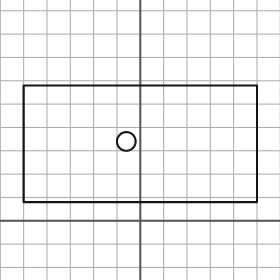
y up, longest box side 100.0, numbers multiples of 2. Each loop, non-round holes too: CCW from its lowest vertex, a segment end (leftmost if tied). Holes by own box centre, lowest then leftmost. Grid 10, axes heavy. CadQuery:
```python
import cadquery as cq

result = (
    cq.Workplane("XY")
    .moveTo(-50.0, 8.0)
    .lineTo(50.0, 8.0)
    .lineTo(50.0, 58.0)
    .lineTo(-50.0, 58.0)
    .close()
    .moveTo(-6.0, 34.0)
    .circle(4.0)
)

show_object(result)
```